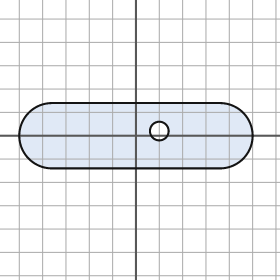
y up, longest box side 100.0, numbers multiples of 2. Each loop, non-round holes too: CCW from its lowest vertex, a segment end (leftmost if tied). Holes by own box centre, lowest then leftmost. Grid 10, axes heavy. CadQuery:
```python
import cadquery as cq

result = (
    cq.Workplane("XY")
    .moveTo(-36.0, -14.0)
    .lineTo(36.0, -14.0)
    .threePointArc((50.0, 0.0), (36.0, 14.0))
    .lineTo(-36.0, 14.0)
    .threePointArc((-50.0, 0.0), (-36.0, -14.0))
    .close()
    .moveTo(10.0, 2.0)
    .circle(4.0)
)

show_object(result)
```